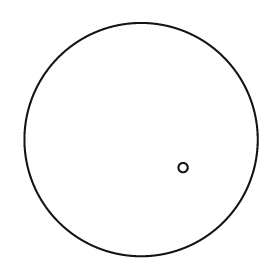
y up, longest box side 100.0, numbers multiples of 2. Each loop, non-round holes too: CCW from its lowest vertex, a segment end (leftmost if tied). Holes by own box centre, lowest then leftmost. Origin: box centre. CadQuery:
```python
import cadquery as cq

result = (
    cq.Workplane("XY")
    .moveTo(0.0, 0.0)
    .circle(50.0)
    .moveTo(18.0, -12.0)
    .circle(2.0)
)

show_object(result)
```